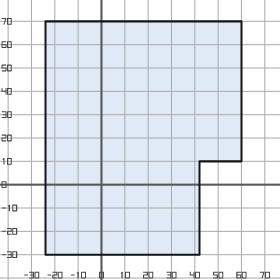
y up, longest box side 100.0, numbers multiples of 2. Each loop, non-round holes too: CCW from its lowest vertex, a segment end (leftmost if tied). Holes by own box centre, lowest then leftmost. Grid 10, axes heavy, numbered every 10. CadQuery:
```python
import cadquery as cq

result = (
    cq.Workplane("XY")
    .moveTo(-24.0, -30.0)
    .lineTo(42.0, -30.0)
    .lineTo(42.0, 10.0)
    .lineTo(60.0, 10.0)
    .lineTo(60.0, 70.0)
    .lineTo(-24.0, 70.0)
    .close()
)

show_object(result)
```